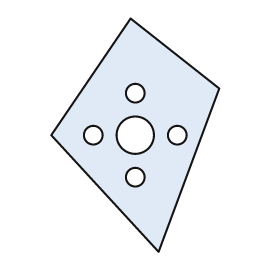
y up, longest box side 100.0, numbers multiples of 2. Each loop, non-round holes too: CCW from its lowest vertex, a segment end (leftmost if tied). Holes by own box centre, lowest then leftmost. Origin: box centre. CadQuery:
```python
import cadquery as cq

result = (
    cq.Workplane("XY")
    .moveTo(10.0, -50.0)
    .lineTo(36.0, 20.0)
    .lineTo(-2.0, 50.0)
    .lineTo(-36.0, 0.0)
    .close()
    .moveTo(0.0, -18.0)
    .circle(4.0)
    .moveTo(-18.0, 0.0)
    .circle(4.0)
    .moveTo(0.0, 0.0)
    .circle(8.0)
    .moveTo(18.0, 0.0)
    .circle(4.0)
    .moveTo(0.0, 18.0)
    .circle(4.0)
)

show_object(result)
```